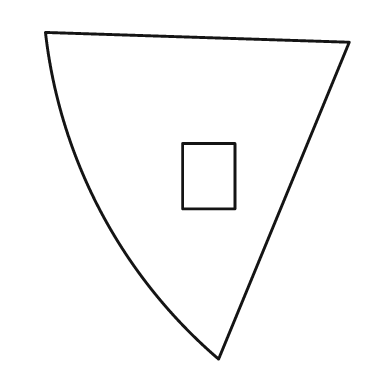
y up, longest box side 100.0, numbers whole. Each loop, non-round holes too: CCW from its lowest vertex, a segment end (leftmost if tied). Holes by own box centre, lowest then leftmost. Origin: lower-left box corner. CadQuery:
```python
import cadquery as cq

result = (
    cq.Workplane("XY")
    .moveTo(53.0, 0.0)
    .lineTo(93.0, 97.0)
    .lineTo(0.0, 100.0)
    .threePointArc((17.0, 45.0), (53.0, 0.0))
    .close()
    .moveTo(42.0, 46.0)
    .lineTo(58.0, 46.0)
    .lineTo(58.0, 66.0)
    .lineTo(42.0, 66.0)
    .close()
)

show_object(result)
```